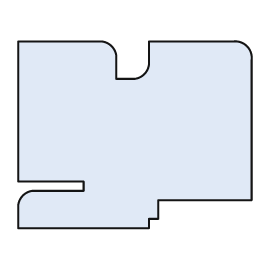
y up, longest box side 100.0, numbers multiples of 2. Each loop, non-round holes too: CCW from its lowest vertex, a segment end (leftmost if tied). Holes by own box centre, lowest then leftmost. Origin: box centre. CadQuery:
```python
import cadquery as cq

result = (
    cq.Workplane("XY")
    .moveTo(-50.0, -40.0)
    .lineTo(6.0, -40.0)
    .lineTo(6.0, -36.0)
    .lineTo(10.0, -36.0)
    .lineTo(10.0, -28.0)
    .lineTo(50.0, -28.0)
    .lineTo(50.0, 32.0)
    .threePointArc((48.0, 38.0), (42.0, 40.0))
    .lineTo(6.0, 40.0)
    .lineTo(6.0, 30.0)
    .threePointArc((4.0, 26.0), (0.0, 24.0))
    .lineTo(-8.0, 24.0)
    .lineTo(-8.0, 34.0)
    .threePointArc((-10.0, 38.0), (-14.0, 40.0))
    .lineTo(-50.0, 40.0)
    .lineTo(-50.0, -20.0)
    .lineTo(-22.0, -20.0)
    .lineTo(-22.0, -24.0)
    .lineTo(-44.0, -24.0)
    .threePointArc((-48.0, -26.0), (-50.0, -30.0))
    .close()
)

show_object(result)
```